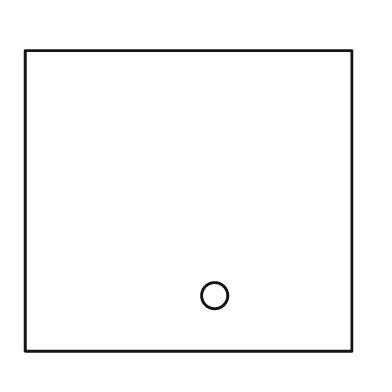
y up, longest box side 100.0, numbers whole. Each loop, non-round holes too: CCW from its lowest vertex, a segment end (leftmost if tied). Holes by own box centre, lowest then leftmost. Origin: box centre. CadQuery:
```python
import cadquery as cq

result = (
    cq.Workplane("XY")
    .moveTo(-50.0, -46.0)
    .lineTo(50.0, -46.0)
    .lineTo(50.0, 46.0)
    .lineTo(-50.0, 46.0)
    .close()
    .moveTo(8.0, -29.0)
    .circle(4.0)
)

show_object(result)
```